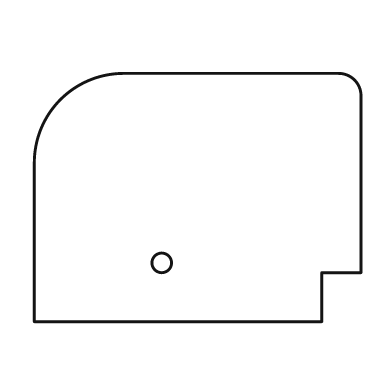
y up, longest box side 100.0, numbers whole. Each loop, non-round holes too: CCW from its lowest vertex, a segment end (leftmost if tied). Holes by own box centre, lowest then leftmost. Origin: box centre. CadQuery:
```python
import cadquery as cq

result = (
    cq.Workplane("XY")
    .moveTo(-50.0, -38.0)
    .lineTo(38.0, -38.0)
    .lineTo(38.0, -23.0)
    .lineTo(50.0, -23.0)
    .lineTo(50.0, 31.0)
    .threePointArc((48.0, 36.0), (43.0, 38.0))
    .lineTo(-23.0, 38.0)
    .threePointArc((-42.0, 30.0), (-50.0, 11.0))
    .close()
    .moveTo(-11.0, -20.0)
    .circle(3.0)
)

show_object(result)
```